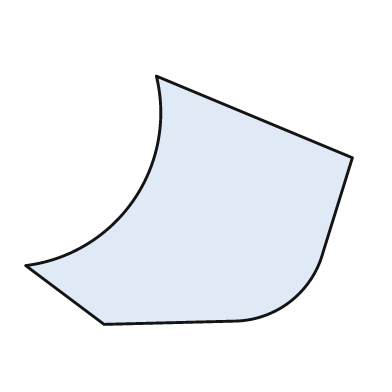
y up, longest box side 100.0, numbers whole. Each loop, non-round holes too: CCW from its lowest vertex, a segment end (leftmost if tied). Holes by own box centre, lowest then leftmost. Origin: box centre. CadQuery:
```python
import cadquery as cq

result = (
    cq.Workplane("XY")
    .moveTo(-26.0, -38.0)
    .lineTo(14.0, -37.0)
    .threePointArc((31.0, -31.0), (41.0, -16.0))
    .lineTo(50.0, 13.0)
    .lineTo(-10.0, 38.0)
    .threePointArc((-17.0, 0.0), (-50.0, -20.0))
    .close()
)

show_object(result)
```